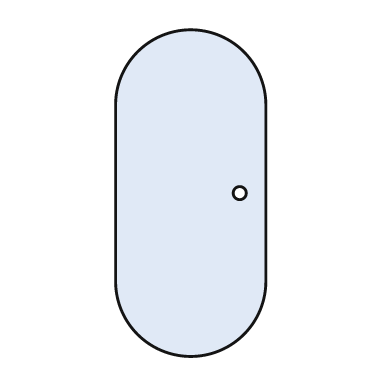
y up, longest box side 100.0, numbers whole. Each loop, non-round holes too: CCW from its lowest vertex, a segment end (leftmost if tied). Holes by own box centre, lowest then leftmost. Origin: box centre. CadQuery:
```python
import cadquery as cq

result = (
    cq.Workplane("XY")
    .moveTo(-23.0, -27.0)
    .threePointArc((0.0, -50.0), (23.0, -27.0))
    .lineTo(23.0, 27.0)
    .threePointArc((0.0, 50.0), (-23.0, 27.0))
    .close()
    .moveTo(15.0, 0.0)
    .circle(2.0)
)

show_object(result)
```